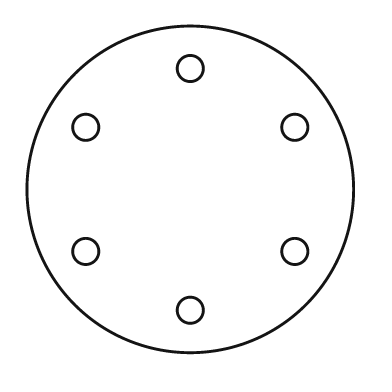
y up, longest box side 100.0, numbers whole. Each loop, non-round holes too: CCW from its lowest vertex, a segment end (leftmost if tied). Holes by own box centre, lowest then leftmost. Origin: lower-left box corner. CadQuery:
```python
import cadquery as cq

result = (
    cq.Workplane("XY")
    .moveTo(50.0, 50.0)
    .circle(50.0)
    .moveTo(50.0, 13.0)
    .circle(4.0)
    .moveTo(18.0, 31.0)
    .circle(4.0)
    .moveTo(82.0, 31.0)
    .circle(4.0)
    .moveTo(18.0, 69.0)
    .circle(4.0)
    .moveTo(82.0, 69.0)
    .circle(4.0)
    .moveTo(50.0, 87.0)
    .circle(4.0)
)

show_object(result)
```